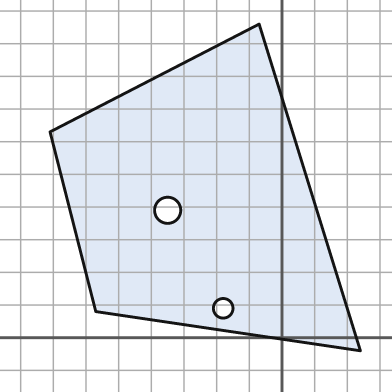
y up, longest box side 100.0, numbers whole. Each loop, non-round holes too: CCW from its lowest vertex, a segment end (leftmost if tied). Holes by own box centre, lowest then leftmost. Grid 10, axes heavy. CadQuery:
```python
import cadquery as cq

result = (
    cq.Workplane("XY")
    .moveTo(24.0, -4.0)
    .lineTo(-7.0, 96.0)
    .lineTo(-71.0, 63.0)
    .lineTo(-57.0, 8.0)
    .close()
    .moveTo(-18.0, 9.0)
    .circle(3.0)
    .moveTo(-35.0, 39.0)
    .circle(4.0)
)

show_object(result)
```